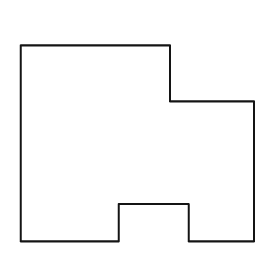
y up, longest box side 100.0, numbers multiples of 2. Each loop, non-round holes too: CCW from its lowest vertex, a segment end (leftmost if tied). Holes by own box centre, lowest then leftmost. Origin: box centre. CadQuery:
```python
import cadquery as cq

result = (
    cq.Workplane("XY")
    .moveTo(-50.0, -42.0)
    .lineTo(-8.0, -42.0)
    .lineTo(-8.0, -26.0)
    .lineTo(22.0, -26.0)
    .lineTo(22.0, -42.0)
    .lineTo(50.0, -42.0)
    .lineTo(50.0, 18.0)
    .lineTo(14.0, 18.0)
    .lineTo(14.0, 42.0)
    .lineTo(-50.0, 42.0)
    .close()
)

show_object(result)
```